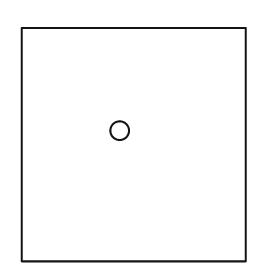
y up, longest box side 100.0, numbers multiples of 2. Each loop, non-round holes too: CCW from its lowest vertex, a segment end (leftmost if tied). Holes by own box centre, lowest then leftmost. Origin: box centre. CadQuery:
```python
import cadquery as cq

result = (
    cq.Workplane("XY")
    .moveTo(-48.0, -50.0)
    .lineTo(48.0, -50.0)
    .lineTo(48.0, 50.0)
    .lineTo(-48.0, 50.0)
    .close()
    .moveTo(-6.0, 6.0)
    .circle(4.0)
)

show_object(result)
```